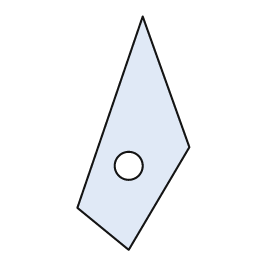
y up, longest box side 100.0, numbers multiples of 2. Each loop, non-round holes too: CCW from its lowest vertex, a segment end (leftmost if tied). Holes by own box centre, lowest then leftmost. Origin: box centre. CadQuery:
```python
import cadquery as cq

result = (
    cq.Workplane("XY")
    .moveTo(-2.0, -50.0)
    .lineTo(24.0, -6.0)
    .lineTo(4.0, 50.0)
    .lineTo(-24.0, -32.0)
    .close()
    .moveTo(-2.0, -14.0)
    .circle(6.0)
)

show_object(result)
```